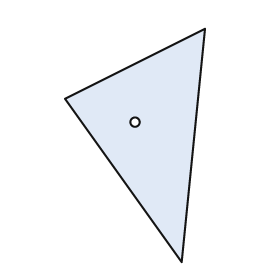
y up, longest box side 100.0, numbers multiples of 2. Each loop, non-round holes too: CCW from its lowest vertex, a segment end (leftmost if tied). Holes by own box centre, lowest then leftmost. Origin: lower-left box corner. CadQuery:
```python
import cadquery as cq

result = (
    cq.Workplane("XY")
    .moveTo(50.0, 0.0)
    .lineTo(60.0, 100.0)
    .lineTo(0.0, 70.0)
    .close()
    .moveTo(30.0, 60.0)
    .circle(2.0)
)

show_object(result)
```